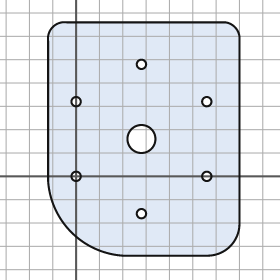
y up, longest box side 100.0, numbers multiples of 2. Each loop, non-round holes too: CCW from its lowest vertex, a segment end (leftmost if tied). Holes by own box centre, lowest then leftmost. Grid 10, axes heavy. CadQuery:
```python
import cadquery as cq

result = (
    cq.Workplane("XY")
    .moveTo(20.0, -34.0)
    .lineTo(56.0, -34.0)
    .threePointArc((66.0, -30.0), (70.0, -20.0))
    .lineTo(70.0, 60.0)
    .threePointArc((68.0, 64.0), (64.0, 66.0))
    .lineTo(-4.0, 66.0)
    .threePointArc((-10.0, 64.0), (-12.0, 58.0))
    .lineTo(-12.0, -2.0)
    .threePointArc((-2.0, -24.0), (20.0, -34.0))
    .close()
    .moveTo(28.0, -16.0)
    .circle(2.0)
    .moveTo(0.0, 0.0)
    .circle(2.0)
    .moveTo(56.0, 0.0)
    .circle(2.0)
    .moveTo(28.0, 16.0)
    .circle(6.0)
    .moveTo(0.0, 32.0)
    .circle(2.0)
    .moveTo(56.0, 32.0)
    .circle(2.0)
    .moveTo(28.0, 48.0)
    .circle(2.0)
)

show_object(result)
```